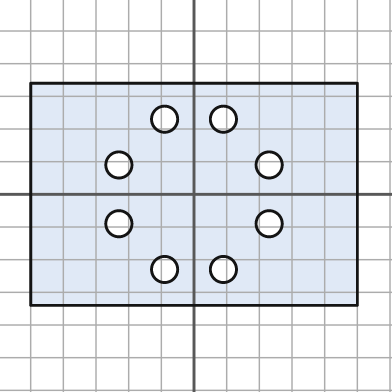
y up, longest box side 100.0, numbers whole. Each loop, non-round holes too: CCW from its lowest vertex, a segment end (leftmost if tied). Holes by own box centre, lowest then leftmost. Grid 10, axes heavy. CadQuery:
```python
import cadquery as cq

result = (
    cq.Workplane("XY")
    .moveTo(-50.0, -34.0)
    .lineTo(50.0, -34.0)
    .lineTo(50.0, 34.0)
    .lineTo(-50.0, 34.0)
    .close()
    .moveTo(-9.0, -23.0)
    .circle(4.0)
    .moveTo(9.0, -23.0)
    .circle(4.0)
    .moveTo(-23.0, -9.0)
    .circle(4.0)
    .moveTo(23.0, -9.0)
    .circle(4.0)
    .moveTo(-23.0, 9.0)
    .circle(4.0)
    .moveTo(23.0, 9.0)
    .circle(4.0)
    .moveTo(-9.0, 23.0)
    .circle(4.0)
    .moveTo(9.0, 23.0)
    .circle(4.0)
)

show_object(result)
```